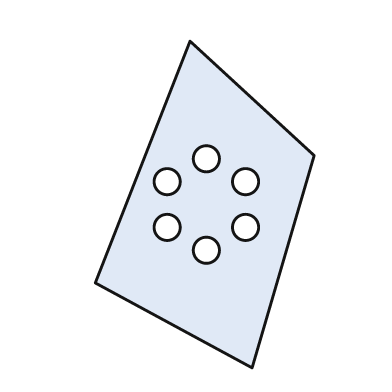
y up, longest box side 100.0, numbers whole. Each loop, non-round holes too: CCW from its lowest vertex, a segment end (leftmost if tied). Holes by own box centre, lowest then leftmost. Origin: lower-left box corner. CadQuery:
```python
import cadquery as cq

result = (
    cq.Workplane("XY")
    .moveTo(48.0, 0.0)
    .lineTo(67.0, 65.0)
    .lineTo(29.0, 100.0)
    .lineTo(0.0, 26.0)
    .close()
    .moveTo(34.0, 36.0)
    .circle(4.0)
    .moveTo(22.0, 43.0)
    .circle(4.0)
    .moveTo(46.0, 43.0)
    .circle(4.0)
    .moveTo(22.0, 57.0)
    .circle(4.0)
    .moveTo(46.0, 57.0)
    .circle(4.0)
    .moveTo(34.0, 64.0)
    .circle(4.0)
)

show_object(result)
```